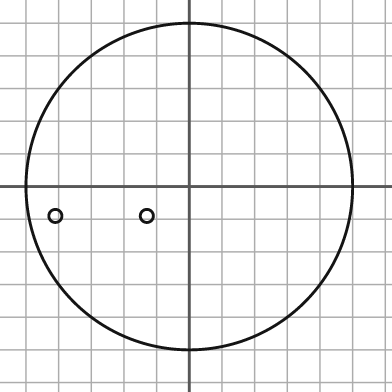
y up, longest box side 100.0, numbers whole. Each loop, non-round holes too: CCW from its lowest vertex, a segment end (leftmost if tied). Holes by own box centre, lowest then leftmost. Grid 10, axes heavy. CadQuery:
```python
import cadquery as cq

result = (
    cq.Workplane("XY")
    .moveTo(0.0, 0.0)
    .circle(50.0)
    .moveTo(-41.0, -9.0)
    .circle(2.0)
    .moveTo(-13.0, -9.0)
    .circle(2.0)
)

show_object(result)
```